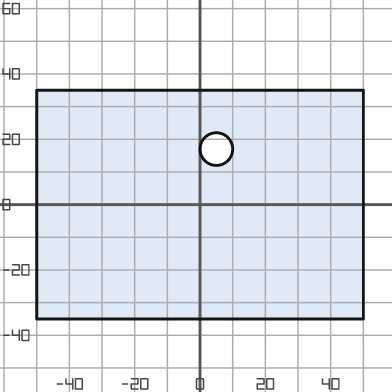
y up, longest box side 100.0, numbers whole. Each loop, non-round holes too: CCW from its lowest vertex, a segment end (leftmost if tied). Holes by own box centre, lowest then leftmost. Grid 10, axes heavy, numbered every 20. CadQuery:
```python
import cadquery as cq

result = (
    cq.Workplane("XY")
    .moveTo(-50.0, -35.0)
    .lineTo(50.0, -35.0)
    .lineTo(50.0, 35.0)
    .lineTo(-50.0, 35.0)
    .close()
    .moveTo(5.0, 17.0)
    .circle(5.0)
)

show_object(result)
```